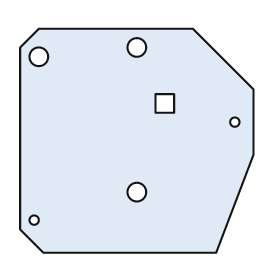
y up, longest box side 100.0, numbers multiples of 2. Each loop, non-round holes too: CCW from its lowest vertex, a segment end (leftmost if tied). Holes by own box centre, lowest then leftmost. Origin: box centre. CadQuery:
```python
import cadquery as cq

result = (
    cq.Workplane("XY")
    .moveTo(-40.0, -48.0)
    .lineTo(34.0, -48.0)
    .lineTo(50.0, -6.0)
    .lineTo(50.0, 22.0)
    .lineTo(24.0, 48.0)
    .lineTo(-42.0, 48.0)
    .lineTo(-50.0, 40.0)
    .lineTo(-50.0, -38.0)
    .close()
    .moveTo(-44.0, -34.0)
    .circle(2.0)
    .moveTo(0.0, -22.0)
    .circle(4.0)
    .moveTo(42.0, 8.0)
    .circle(2.0)
    .moveTo(8.0, 12.0)
    .lineTo(16.0, 12.0)
    .lineTo(16.0, 20.0)
    .lineTo(8.0, 20.0)
    .close()
    .moveTo(-42.0, 36.0)
    .circle(4.0)
    .moveTo(0.0, 40.0)
    .circle(4.0)
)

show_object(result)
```